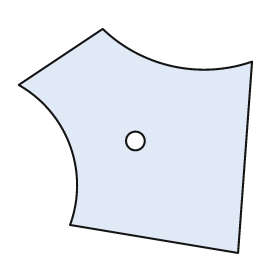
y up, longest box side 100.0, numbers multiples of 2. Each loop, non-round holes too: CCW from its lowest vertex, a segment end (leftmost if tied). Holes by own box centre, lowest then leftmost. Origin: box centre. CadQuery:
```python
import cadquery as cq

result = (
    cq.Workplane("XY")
    .moveTo(44.0, -48.0)
    .lineTo(50.0, 34.0)
    .threePointArc((16.0, 32.0), (-14.0, 48.0))
    .lineTo(-50.0, 24.0)
    .threePointArc((-28.0, -2.0), (-28.0, -36.0))
    .close()
    .moveTo(0.0, 0.0)
    .circle(4.0)
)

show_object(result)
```